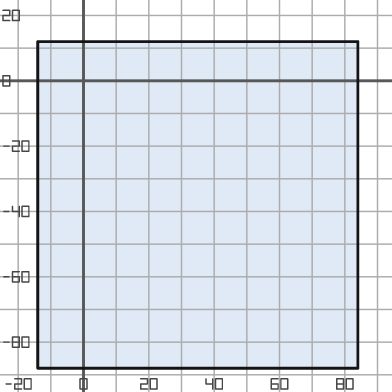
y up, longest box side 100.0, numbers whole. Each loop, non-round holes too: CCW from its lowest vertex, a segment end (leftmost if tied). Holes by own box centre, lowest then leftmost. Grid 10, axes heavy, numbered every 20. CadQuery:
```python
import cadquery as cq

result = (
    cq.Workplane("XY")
    .moveTo(-14.0, -88.0)
    .lineTo(84.0, -88.0)
    .lineTo(84.0, 12.0)
    .lineTo(-14.0, 12.0)
    .close()
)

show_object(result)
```